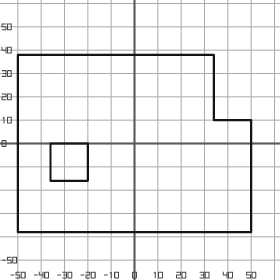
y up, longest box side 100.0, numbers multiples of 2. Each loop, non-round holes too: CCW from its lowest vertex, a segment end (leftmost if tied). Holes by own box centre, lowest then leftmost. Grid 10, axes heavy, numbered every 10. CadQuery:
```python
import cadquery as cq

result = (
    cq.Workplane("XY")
    .moveTo(-50.0, -38.0)
    .lineTo(50.0, -38.0)
    .lineTo(50.0, 10.0)
    .lineTo(34.0, 10.0)
    .lineTo(34.0, 38.0)
    .lineTo(-50.0, 38.0)
    .close()
    .moveTo(-36.0, -16.0)
    .lineTo(-20.0, -16.0)
    .lineTo(-20.0, 0.0)
    .lineTo(-36.0, 0.0)
    .close()
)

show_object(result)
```